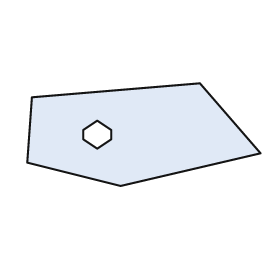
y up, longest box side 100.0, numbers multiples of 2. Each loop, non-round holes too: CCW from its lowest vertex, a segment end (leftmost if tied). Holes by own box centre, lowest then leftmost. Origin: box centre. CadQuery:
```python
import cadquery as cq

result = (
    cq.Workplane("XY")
    .moveTo(-10.0, -22.0)
    .lineTo(50.0, -8.0)
    .lineTo(24.0, 22.0)
    .lineTo(-48.0, 16.0)
    .lineTo(-50.0, -12.0)
    .close()
    .moveTo(-20.0, -6.0)
    .lineTo(-14.0, -2.0)
    .lineTo(-14.0, 2.0)
    .lineTo(-20.0, 6.0)
    .lineTo(-26.0, 2.0)
    .lineTo(-26.0, -2.0)
    .close()
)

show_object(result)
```